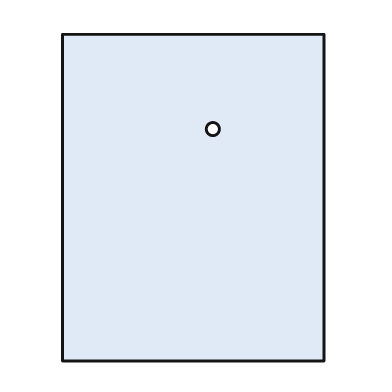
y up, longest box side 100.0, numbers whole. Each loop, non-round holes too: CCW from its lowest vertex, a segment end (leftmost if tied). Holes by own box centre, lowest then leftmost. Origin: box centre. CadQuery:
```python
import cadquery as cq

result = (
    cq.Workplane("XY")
    .moveTo(-40.0, -50.0)
    .lineTo(40.0, -50.0)
    .lineTo(40.0, 50.0)
    .lineTo(-40.0, 50.0)
    .close()
    .moveTo(6.0, 21.0)
    .circle(2.0)
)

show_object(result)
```